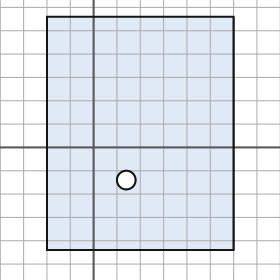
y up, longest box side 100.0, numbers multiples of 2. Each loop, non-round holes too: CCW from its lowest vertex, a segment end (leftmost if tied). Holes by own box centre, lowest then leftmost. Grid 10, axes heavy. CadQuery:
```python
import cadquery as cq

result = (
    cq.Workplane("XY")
    .moveTo(-20.0, -44.0)
    .lineTo(60.0, -44.0)
    .lineTo(60.0, 56.0)
    .lineTo(-20.0, 56.0)
    .close()
    .moveTo(14.0, -14.0)
    .circle(4.0)
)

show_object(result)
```